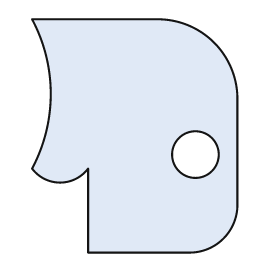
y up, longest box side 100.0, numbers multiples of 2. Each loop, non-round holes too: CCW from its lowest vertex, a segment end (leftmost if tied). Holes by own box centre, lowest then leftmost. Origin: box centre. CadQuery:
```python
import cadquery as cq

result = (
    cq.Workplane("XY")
    .moveTo(-20.0, -50.0)
    .lineTo(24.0, -50.0)
    .threePointArc((38.0, -44.0), (44.0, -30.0))
    .lineTo(44.0, 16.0)
    .threePointArc((34.0, 40.0), (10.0, 50.0))
    .lineTo(-44.0, 50.0)
    .threePointArc((-36.0, 18.0), (-44.0, -14.0))
    .threePointArc((-32.0, -20.0), (-20.0, -14.0))
    .close()
    .moveTo(26.0, -8.0)
    .circle(10.0)
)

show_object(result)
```